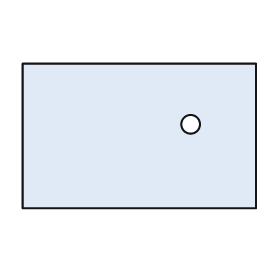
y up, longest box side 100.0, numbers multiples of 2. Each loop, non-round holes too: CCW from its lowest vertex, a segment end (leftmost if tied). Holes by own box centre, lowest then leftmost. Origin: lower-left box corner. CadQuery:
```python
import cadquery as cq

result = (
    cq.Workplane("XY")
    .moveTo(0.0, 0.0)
    .lineTo(100.0, 0.0)
    .lineTo(100.0, 62.0)
    .lineTo(0.0, 62.0)
    .close()
    .moveTo(72.0, 36.0)
    .circle(4.0)
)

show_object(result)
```